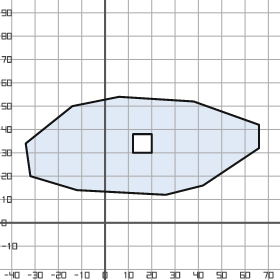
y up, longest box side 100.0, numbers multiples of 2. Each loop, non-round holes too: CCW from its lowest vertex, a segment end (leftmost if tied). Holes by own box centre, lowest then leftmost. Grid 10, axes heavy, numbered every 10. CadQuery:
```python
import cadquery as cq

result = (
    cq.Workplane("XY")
    .moveTo(26.0, 12.0)
    .lineTo(42.0, 16.0)
    .lineTo(66.0, 32.0)
    .lineTo(66.0, 42.0)
    .lineTo(38.0, 52.0)
    .lineTo(6.0, 54.0)
    .lineTo(-14.0, 50.0)
    .lineTo(-34.0, 34.0)
    .lineTo(-32.0, 20.0)
    .lineTo(-12.0, 14.0)
    .close()
    .moveTo(12.0, 30.0)
    .lineTo(20.0, 30.0)
    .lineTo(20.0, 38.0)
    .lineTo(12.0, 38.0)
    .close()
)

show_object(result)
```